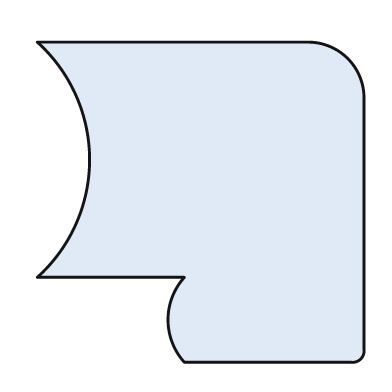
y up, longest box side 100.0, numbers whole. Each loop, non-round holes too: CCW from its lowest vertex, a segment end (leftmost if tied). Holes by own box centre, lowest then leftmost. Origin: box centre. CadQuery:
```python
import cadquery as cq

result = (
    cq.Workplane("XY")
    .moveTo(-5.0, -49.0)
    .lineTo(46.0, -49.0)
    .threePointArc((49.0, -48.0), (50.0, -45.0))
    .lineTo(50.0, 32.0)
    .threePointArc((45.0, 44.0), (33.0, 49.0))
    .lineTo(-50.0, 49.0)
    .threePointArc((-34.0, 13.0), (-50.0, -23.0))
    .lineTo(-5.0, -23.0)
    .threePointArc((-10.0, -36.0), (-5.0, -49.0))
    .close()
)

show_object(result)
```